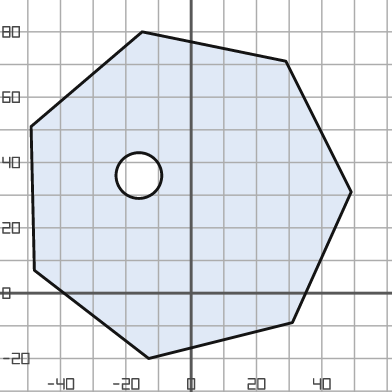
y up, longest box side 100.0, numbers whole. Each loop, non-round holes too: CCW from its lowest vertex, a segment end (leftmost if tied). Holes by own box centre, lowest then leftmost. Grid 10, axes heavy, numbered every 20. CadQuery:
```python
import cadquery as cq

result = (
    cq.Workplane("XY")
    .moveTo(-13.0, -20.0)
    .lineTo(31.0, -9.0)
    .lineTo(49.0, 31.0)
    .lineTo(29.0, 71.0)
    .lineTo(-15.0, 80.0)
    .lineTo(-49.0, 51.0)
    .lineTo(-48.0, 7.0)
    .close()
    .moveTo(-16.0, 36.0)
    .circle(7.0)
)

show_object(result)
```